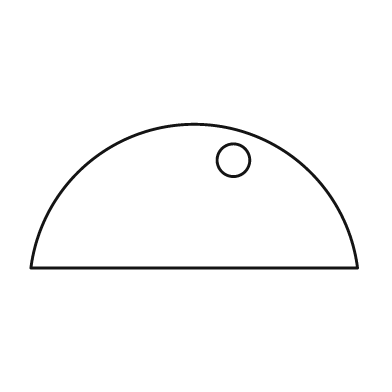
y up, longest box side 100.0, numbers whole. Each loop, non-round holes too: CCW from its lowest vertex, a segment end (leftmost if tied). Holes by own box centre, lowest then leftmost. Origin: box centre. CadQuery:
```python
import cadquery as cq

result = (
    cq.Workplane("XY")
    .moveTo(-50.0, -22.0)
    .lineTo(50.0, -22.0)
    .threePointArc((0.0, 22.0), (-50.0, -22.0))
    .close()
    .moveTo(12.0, 11.0)
    .circle(5.0)
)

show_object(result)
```